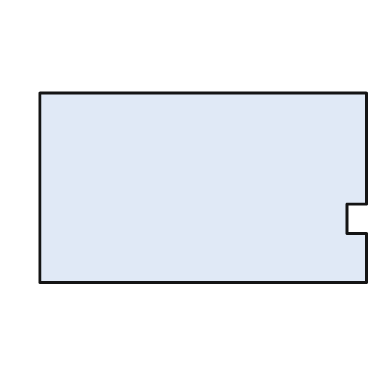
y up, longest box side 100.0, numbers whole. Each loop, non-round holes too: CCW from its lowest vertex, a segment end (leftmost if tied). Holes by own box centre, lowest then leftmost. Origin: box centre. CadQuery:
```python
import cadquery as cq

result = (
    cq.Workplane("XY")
    .moveTo(-50.0, -29.0)
    .lineTo(50.0, -29.0)
    .lineTo(50.0, -14.0)
    .lineTo(44.0, -14.0)
    .lineTo(44.0, -5.0)
    .lineTo(50.0, -5.0)
    .lineTo(50.0, 29.0)
    .lineTo(-50.0, 29.0)
    .close()
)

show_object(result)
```